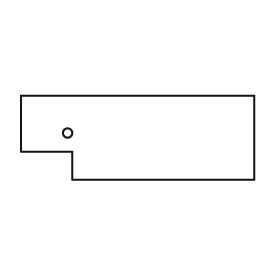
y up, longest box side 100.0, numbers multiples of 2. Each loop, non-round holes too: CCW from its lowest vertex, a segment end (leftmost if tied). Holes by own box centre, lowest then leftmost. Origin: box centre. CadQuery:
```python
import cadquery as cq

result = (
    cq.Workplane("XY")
    .moveTo(-28.0, -18.0)
    .lineTo(50.0, -18.0)
    .lineTo(50.0, 18.0)
    .lineTo(-50.0, 18.0)
    .lineTo(-50.0, -6.0)
    .lineTo(-28.0, -6.0)
    .close()
    .moveTo(-30.0, 2.0)
    .circle(2.0)
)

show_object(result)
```